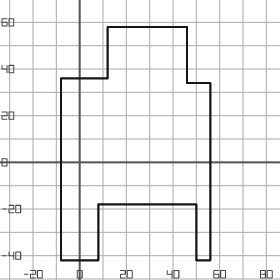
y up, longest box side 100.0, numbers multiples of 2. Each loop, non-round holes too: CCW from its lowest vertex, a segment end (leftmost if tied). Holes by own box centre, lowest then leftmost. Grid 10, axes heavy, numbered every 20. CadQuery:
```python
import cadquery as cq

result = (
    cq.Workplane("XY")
    .moveTo(-8.0, -42.0)
    .lineTo(8.0, -42.0)
    .lineTo(8.0, -18.0)
    .lineTo(50.0, -18.0)
    .lineTo(50.0, -42.0)
    .lineTo(56.0, -42.0)
    .lineTo(56.0, 34.0)
    .lineTo(46.0, 34.0)
    .lineTo(46.0, 58.0)
    .lineTo(12.0, 58.0)
    .lineTo(12.0, 36.0)
    .lineTo(-8.0, 36.0)
    .close()
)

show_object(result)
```